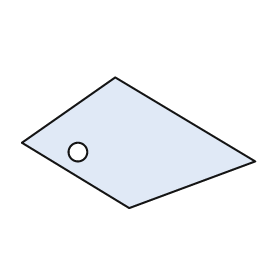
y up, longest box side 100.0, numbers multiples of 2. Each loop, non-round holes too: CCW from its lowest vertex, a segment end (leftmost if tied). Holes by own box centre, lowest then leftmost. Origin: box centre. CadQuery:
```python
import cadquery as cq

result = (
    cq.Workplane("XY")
    .moveTo(-4.0, -28.0)
    .lineTo(50.0, -8.0)
    .lineTo(-10.0, 28.0)
    .lineTo(-50.0, 0.0)
    .close()
    .moveTo(-26.0, -4.0)
    .circle(4.0)
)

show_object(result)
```